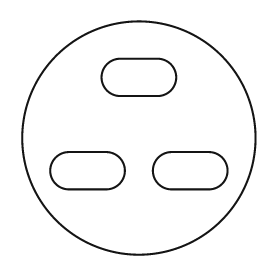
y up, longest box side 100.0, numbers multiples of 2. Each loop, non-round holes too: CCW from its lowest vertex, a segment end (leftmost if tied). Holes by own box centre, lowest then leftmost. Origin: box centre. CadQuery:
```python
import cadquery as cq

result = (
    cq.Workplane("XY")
    .moveTo(0.0, 0.0)
    .circle(50.0)
    .moveTo(-30.0, -22.0)
    .lineTo(-14.0, -22.0)
    .threePointArc((-6.0, -14.0), (-14.0, -6.0))
    .lineTo(-30.0, -6.0)
    .threePointArc((-38.0, -14.0), (-30.0, -22.0))
    .close()
    .moveTo(14.0, -22.0)
    .lineTo(30.0, -22.0)
    .threePointArc((38.0, -14.0), (30.0, -6.0))
    .lineTo(14.0, -6.0)
    .threePointArc((6.0, -14.0), (14.0, -22.0))
    .close()
    .moveTo(-8.0, 18.0)
    .lineTo(8.0, 18.0)
    .threePointArc((16.0, 26.0), (8.0, 34.0))
    .lineTo(-8.0, 34.0)
    .threePointArc((-16.0, 26.0), (-8.0, 18.0))
    .close()
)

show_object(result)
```